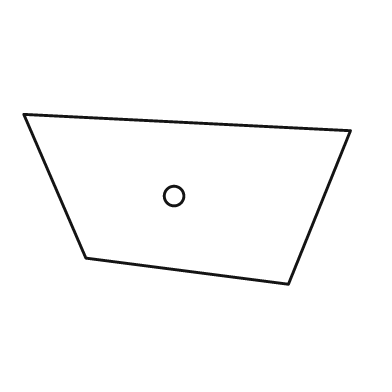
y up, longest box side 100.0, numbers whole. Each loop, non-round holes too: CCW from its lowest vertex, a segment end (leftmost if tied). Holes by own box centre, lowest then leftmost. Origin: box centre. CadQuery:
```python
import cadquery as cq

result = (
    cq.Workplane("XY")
    .moveTo(31.0, -26.0)
    .lineTo(50.0, 21.0)
    .lineTo(-50.0, 26.0)
    .lineTo(-31.0, -18.0)
    .close()
    .moveTo(-4.0, 1.0)
    .circle(3.0)
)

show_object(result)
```